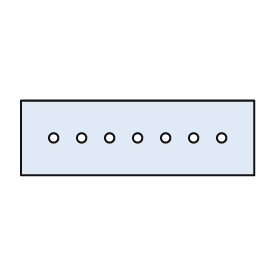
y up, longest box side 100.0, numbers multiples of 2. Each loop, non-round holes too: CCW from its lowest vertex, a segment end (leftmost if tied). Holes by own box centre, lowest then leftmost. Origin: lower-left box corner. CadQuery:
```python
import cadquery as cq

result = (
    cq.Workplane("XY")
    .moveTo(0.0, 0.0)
    .lineTo(100.0, 0.0)
    .lineTo(100.0, 32.0)
    .lineTo(0.0, 32.0)
    .close()
    .moveTo(14.0, 16.0)
    .circle(2.0)
    .moveTo(26.0, 16.0)
    .circle(2.0)
    .moveTo(38.0, 16.0)
    .circle(2.0)
    .moveTo(50.0, 16.0)
    .circle(2.0)
    .moveTo(62.0, 16.0)
    .circle(2.0)
    .moveTo(74.0, 16.0)
    .circle(2.0)
    .moveTo(86.0, 16.0)
    .circle(2.0)
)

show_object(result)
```